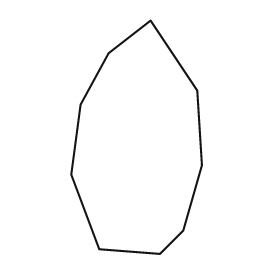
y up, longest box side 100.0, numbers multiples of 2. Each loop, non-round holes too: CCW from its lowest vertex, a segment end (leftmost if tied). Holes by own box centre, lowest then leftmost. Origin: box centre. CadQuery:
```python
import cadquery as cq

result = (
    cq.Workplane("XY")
    .moveTo(10.0, -50.0)
    .lineTo(20.0, -40.0)
    .lineTo(28.0, -12.0)
    .lineTo(26.0, 20.0)
    .lineTo(6.0, 50.0)
    .lineTo(-12.0, 36.0)
    .lineTo(-24.0, 14.0)
    .lineTo(-28.0, -16.0)
    .lineTo(-16.0, -48.0)
    .close()
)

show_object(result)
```